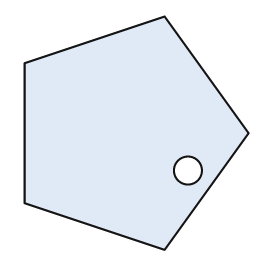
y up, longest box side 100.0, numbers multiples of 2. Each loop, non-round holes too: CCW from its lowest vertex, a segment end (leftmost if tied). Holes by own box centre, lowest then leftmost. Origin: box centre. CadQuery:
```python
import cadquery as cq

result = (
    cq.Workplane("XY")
    .moveTo(12.0, -50.0)
    .lineTo(48.0, 0.0)
    .lineTo(12.0, 50.0)
    .lineTo(-48.0, 30.0)
    .lineTo(-48.0, -30.0)
    .close()
    .moveTo(22.0, -16.0)
    .circle(6.0)
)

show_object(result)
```